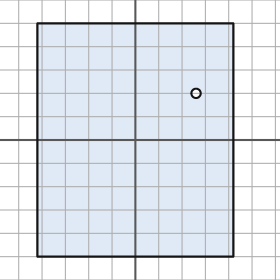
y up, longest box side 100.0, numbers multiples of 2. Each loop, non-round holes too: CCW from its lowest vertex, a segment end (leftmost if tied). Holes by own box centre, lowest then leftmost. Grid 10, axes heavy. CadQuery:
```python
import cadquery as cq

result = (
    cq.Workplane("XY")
    .moveTo(-42.0, -50.0)
    .lineTo(42.0, -50.0)
    .lineTo(42.0, 50.0)
    .lineTo(-42.0, 50.0)
    .close()
    .moveTo(26.0, 20.0)
    .circle(2.0)
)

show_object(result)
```